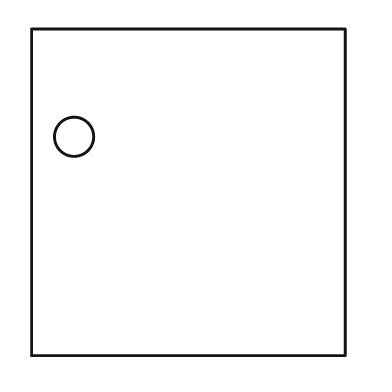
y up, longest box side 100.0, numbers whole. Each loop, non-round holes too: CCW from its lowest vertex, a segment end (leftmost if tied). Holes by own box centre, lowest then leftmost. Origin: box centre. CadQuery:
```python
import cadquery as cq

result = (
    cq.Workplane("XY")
    .moveTo(-48.0, -50.0)
    .lineTo(48.0, -50.0)
    .lineTo(48.0, 50.0)
    .lineTo(-48.0, 50.0)
    .close()
    .moveTo(-35.0, 17.0)
    .circle(6.0)
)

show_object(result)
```